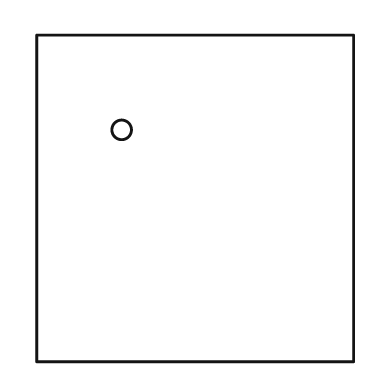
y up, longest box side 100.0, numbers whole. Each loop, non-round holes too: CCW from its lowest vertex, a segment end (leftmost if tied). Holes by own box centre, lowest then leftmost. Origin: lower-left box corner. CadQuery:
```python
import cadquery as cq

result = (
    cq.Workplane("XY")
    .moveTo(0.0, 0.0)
    .lineTo(97.0, 0.0)
    .lineTo(97.0, 100.0)
    .lineTo(0.0, 100.0)
    .close()
    .moveTo(26.0, 71.0)
    .circle(3.0)
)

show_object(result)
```